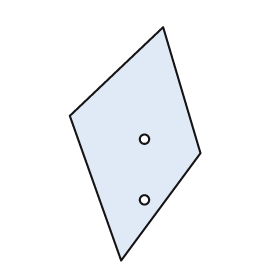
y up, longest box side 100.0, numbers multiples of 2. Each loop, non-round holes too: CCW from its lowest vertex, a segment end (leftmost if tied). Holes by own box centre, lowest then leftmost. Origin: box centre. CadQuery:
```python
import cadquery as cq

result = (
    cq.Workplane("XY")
    .moveTo(-6.0, -50.0)
    .lineTo(28.0, -4.0)
    .lineTo(12.0, 50.0)
    .lineTo(-28.0, 12.0)
    .close()
    .moveTo(4.0, -24.0)
    .circle(2.0)
    .moveTo(4.0, 2.0)
    .circle(2.0)
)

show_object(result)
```